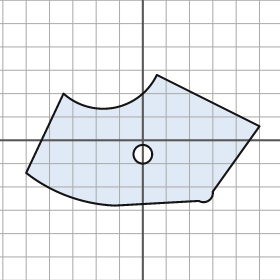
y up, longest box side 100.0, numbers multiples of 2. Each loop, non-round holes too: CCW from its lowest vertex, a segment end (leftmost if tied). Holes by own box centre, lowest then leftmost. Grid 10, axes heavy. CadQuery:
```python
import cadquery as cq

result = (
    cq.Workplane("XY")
    .moveTo(-12.0, -28.0)
    .lineTo(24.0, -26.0)
    .threePointArc((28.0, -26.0), (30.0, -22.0))
    .lineTo(50.0, 6.0)
    .lineTo(6.0, 28.0)
    .threePointArc((-12.0, 14.0), (-34.0, 20.0))
    .lineTo(-50.0, -14.0)
    .threePointArc((-32.0, -24.0), (-12.0, -28.0))
    .close()
    .moveTo(0.0, -6.0)
    .circle(4.0)
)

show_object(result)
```